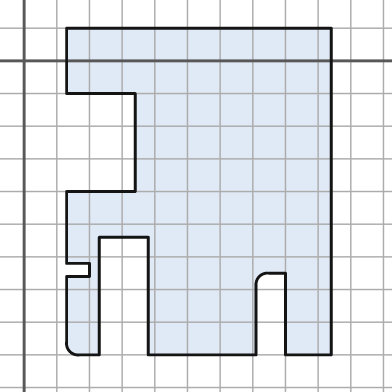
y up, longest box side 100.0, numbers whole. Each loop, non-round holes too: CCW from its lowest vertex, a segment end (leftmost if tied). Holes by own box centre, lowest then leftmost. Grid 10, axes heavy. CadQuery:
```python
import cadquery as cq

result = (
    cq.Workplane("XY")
    .moveTo(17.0, -90.0)
    .lineTo(23.0, -90.0)
    .lineTo(23.0, -54.0)
    .lineTo(38.0, -54.0)
    .lineTo(38.0, -90.0)
    .lineTo(71.0, -90.0)
    .lineTo(71.0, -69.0)
    .threePointArc((72.0, -66.0), (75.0, -65.0))
    .lineTo(80.0, -65.0)
    .lineTo(80.0, -90.0)
    .lineTo(94.0, -90.0)
    .lineTo(94.0, 10.0)
    .lineTo(13.0, 10.0)
    .lineTo(13.0, -10.0)
    .lineTo(34.0, -10.0)
    .lineTo(34.0, -40.0)
    .lineTo(13.0, -40.0)
    .lineTo(13.0, -62.0)
    .lineTo(20.0, -62.0)
    .lineTo(20.0, -66.0)
    .lineTo(13.0, -66.0)
    .lineTo(13.0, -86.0)
    .threePointArc((14.0, -89.0), (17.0, -90.0))
    .close()
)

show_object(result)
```